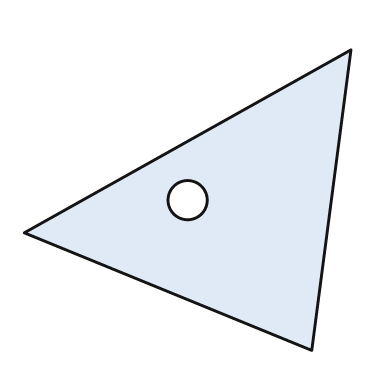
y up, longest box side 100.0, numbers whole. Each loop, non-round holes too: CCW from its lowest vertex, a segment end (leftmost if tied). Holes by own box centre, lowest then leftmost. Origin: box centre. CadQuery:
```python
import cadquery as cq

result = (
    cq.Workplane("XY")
    .moveTo(38.0, -46.0)
    .lineTo(50.0, 46.0)
    .lineTo(-50.0, -10.0)
    .close()
    .moveTo(0.0, 0.0)
    .circle(6.0)
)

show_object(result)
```